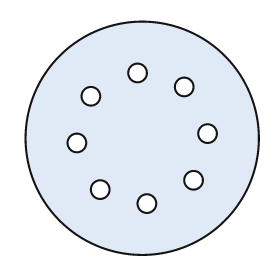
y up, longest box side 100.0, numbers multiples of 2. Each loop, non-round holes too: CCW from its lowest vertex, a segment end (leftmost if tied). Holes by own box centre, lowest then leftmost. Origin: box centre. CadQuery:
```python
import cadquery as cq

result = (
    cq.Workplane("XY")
    .moveTo(0.0, 0.0)
    .circle(50.0)
    .moveTo(2.0, -28.0)
    .circle(4.0)
    .moveTo(-18.0, -22.0)
    .circle(4.0)
    .moveTo(22.0, -18.0)
    .circle(4.0)
    .moveTo(-28.0, -2.0)
    .circle(4.0)
    .moveTo(28.0, 2.0)
    .circle(4.0)
    .moveTo(-22.0, 18.0)
    .circle(4.0)
    .moveTo(18.0, 22.0)
    .circle(4.0)
    .moveTo(-2.0, 28.0)
    .circle(4.0)
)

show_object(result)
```